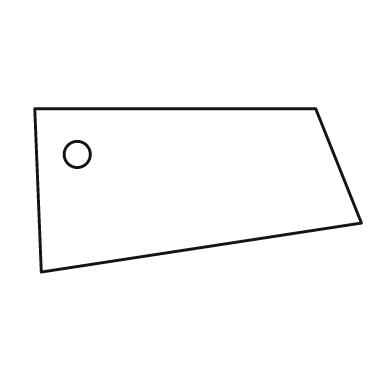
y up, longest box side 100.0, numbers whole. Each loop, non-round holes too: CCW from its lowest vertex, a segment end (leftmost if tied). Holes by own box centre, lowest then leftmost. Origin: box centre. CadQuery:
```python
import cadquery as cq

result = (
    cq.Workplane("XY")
    .moveTo(-48.0, -25.0)
    .lineTo(50.0, -10.0)
    .lineTo(36.0, 25.0)
    .lineTo(-50.0, 25.0)
    .close()
    .moveTo(-37.0, 11.0)
    .circle(4.0)
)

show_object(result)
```